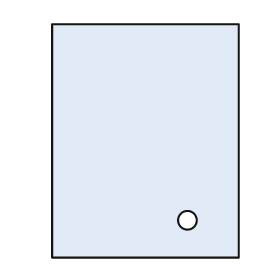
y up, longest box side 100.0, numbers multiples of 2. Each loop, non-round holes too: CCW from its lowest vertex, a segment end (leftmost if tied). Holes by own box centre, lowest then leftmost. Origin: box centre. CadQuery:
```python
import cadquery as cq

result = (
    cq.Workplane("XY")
    .moveTo(-40.0, -50.0)
    .lineTo(40.0, -50.0)
    .lineTo(40.0, 50.0)
    .lineTo(-40.0, 50.0)
    .close()
    .moveTo(18.0, -34.0)
    .circle(4.0)
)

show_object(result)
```